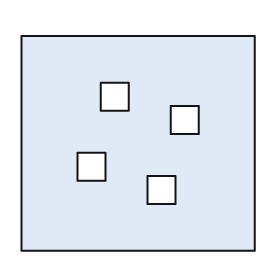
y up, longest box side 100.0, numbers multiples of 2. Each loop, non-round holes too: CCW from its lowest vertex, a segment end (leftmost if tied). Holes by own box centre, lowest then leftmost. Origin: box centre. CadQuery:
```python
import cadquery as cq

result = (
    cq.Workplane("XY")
    .moveTo(-50.0, -46.0)
    .lineTo(50.0, -46.0)
    .lineTo(50.0, 46.0)
    .lineTo(-50.0, 46.0)
    .close()
    .moveTo(4.0, -26.0)
    .lineTo(16.0, -26.0)
    .lineTo(16.0, -14.0)
    .lineTo(4.0, -14.0)
    .close()
    .moveTo(-26.0, -16.0)
    .lineTo(-14.0, -16.0)
    .lineTo(-14.0, -4.0)
    .lineTo(-26.0, -4.0)
    .close()
    .moveTo(14.0, 4.0)
    .lineTo(26.0, 4.0)
    .lineTo(26.0, 16.0)
    .lineTo(14.0, 16.0)
    .close()
    .moveTo(-16.0, 14.0)
    .lineTo(-4.0, 14.0)
    .lineTo(-4.0, 26.0)
    .lineTo(-16.0, 26.0)
    .close()
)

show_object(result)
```